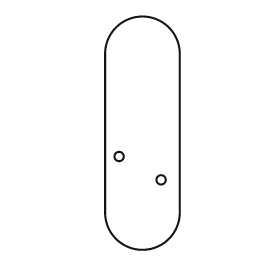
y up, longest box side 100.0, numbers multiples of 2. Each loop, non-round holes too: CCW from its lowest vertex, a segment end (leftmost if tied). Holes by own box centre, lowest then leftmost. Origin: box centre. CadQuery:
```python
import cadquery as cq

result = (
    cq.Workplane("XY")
    .moveTo(-16.0, -34.0)
    .threePointArc((0.0, -50.0), (16.0, -34.0))
    .lineTo(16.0, 34.0)
    .threePointArc((0.0, 50.0), (-16.0, 34.0))
    .close()
    .moveTo(8.0, -20.0)
    .circle(2.0)
    .moveTo(-10.0, -10.0)
    .circle(2.0)
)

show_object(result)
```